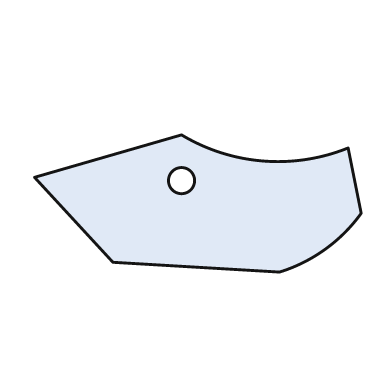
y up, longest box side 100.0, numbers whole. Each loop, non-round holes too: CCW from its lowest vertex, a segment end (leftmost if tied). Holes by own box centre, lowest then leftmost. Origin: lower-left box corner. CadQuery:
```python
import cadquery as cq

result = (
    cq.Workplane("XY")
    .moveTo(75.0, 0.0)
    .threePointArc((89.0, 7.0), (100.0, 18.0))
    .lineTo(96.0, 38.0)
    .threePointArc((70.0, 34.0), (45.0, 42.0))
    .lineTo(0.0, 29.0)
    .lineTo(24.0, 3.0)
    .close()
    .moveTo(45.0, 28.0)
    .circle(4.0)
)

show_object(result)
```